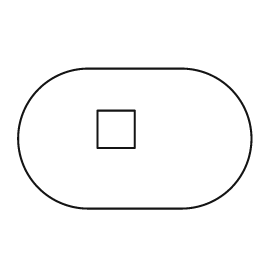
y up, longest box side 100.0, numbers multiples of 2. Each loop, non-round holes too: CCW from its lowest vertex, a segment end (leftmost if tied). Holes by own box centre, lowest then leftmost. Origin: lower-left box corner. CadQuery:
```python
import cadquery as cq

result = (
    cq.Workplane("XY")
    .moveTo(30.0, 0.0)
    .lineTo(70.0, 0.0)
    .threePointArc((100.0, 30.0), (70.0, 60.0))
    .lineTo(30.0, 60.0)
    .threePointArc((0.0, 30.0), (30.0, 0.0))
    .close()
    .moveTo(34.0, 26.0)
    .lineTo(50.0, 26.0)
    .lineTo(50.0, 42.0)
    .lineTo(34.0, 42.0)
    .close()
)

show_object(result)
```